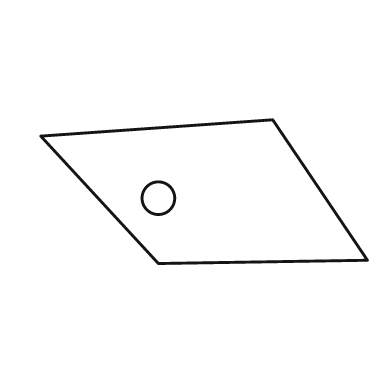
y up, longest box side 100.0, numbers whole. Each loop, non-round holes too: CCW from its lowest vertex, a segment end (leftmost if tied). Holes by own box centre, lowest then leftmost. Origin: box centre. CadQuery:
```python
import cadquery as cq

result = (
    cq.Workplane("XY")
    .moveTo(-14.0, -22.0)
    .lineTo(50.0, -21.0)
    .lineTo(21.0, 22.0)
    .lineTo(-50.0, 17.0)
    .close()
    .moveTo(-14.0, -2.0)
    .circle(5.0)
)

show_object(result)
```